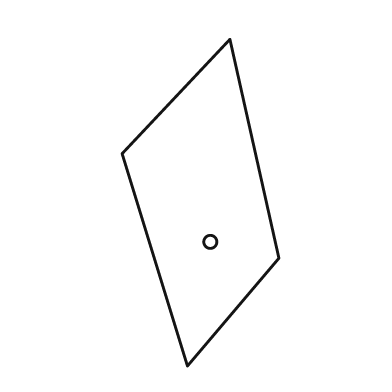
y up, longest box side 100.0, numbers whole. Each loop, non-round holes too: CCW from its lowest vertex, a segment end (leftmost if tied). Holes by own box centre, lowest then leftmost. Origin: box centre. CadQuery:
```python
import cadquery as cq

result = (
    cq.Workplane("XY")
    .moveTo(-4.0, -50.0)
    .lineTo(24.0, -17.0)
    .lineTo(9.0, 50.0)
    .lineTo(-24.0, 15.0)
    .close()
    .moveTo(3.0, -12.0)
    .circle(2.0)
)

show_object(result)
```